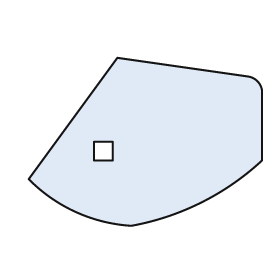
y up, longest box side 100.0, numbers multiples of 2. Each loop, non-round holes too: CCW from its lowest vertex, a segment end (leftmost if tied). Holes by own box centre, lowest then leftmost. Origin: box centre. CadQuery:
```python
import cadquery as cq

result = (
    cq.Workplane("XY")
    .moveTo(-6.0, -36.0)
    .threePointArc((24.0, -26.0), (50.0, -8.0))
    .lineTo(50.0, 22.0)
    .threePointArc((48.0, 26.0), (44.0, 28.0))
    .lineTo(-12.0, 36.0)
    .lineTo(-50.0, -16.0)
    .threePointArc((-30.0, -30.0), (-6.0, -36.0))
    .close()
    .moveTo(-22.0, -8.0)
    .lineTo(-14.0, -8.0)
    .lineTo(-14.0, 0.0)
    .lineTo(-22.0, 0.0)
    .close()
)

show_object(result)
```